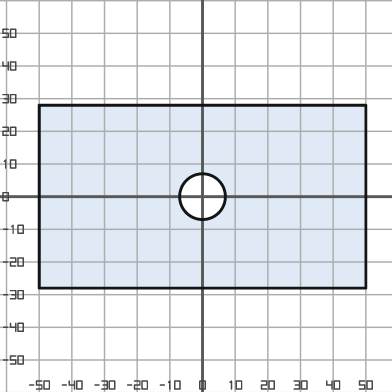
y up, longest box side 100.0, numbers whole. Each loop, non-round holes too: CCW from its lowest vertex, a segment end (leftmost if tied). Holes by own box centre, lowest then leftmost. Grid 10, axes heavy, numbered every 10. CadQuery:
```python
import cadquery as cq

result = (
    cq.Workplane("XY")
    .moveTo(-50.0, -28.0)
    .lineTo(50.0, -28.0)
    .lineTo(50.0, 28.0)
    .lineTo(-50.0, 28.0)
    .close()
    .moveTo(0.0, 0.0)
    .circle(7.0)
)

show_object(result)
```